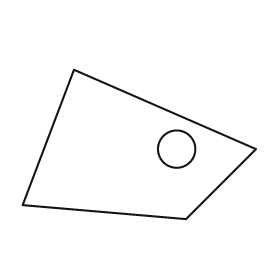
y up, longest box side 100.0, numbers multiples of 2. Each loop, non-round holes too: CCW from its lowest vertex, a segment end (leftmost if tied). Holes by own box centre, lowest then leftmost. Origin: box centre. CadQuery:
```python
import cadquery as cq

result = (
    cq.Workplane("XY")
    .moveTo(20.0, -32.0)
    .lineTo(50.0, -2.0)
    .lineTo(-28.0, 32.0)
    .lineTo(-50.0, -26.0)
    .close()
    .moveTo(16.0, -2.0)
    .circle(8.0)
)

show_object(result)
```